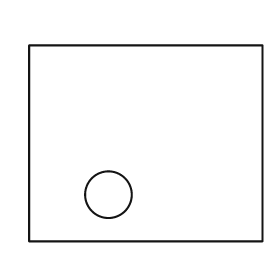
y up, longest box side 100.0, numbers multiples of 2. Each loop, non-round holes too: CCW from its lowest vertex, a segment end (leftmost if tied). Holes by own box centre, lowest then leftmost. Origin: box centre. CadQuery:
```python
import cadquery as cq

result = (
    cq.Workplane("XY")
    .moveTo(-50.0, -42.0)
    .lineTo(50.0, -42.0)
    .lineTo(50.0, 42.0)
    .lineTo(-50.0, 42.0)
    .close()
    .moveTo(-16.0, -22.0)
    .circle(10.0)
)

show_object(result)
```